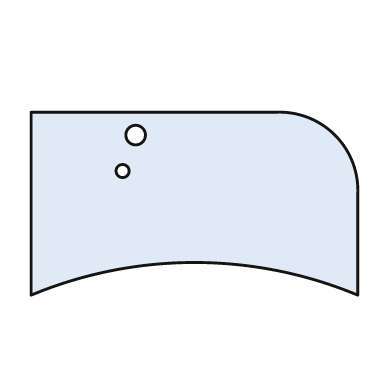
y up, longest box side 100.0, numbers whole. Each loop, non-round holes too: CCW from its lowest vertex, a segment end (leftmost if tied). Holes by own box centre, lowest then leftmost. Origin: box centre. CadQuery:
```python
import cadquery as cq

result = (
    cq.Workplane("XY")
    .moveTo(-50.0, -28.0)
    .threePointArc((0.0, -18.0), (50.0, -28.0))
    .lineTo(50.0, 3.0)
    .threePointArc((43.0, 21.0), (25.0, 28.0))
    .lineTo(-50.0, 28.0)
    .close()
    .moveTo(-22.0, 10.0)
    .circle(2.0)
    .moveTo(-18.0, 21.0)
    .circle(3.0)
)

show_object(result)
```